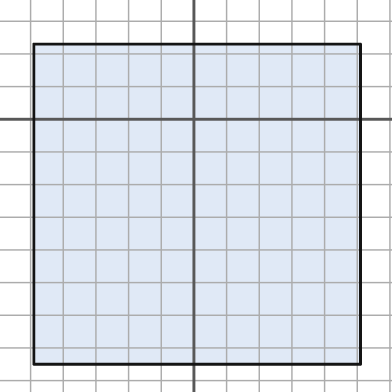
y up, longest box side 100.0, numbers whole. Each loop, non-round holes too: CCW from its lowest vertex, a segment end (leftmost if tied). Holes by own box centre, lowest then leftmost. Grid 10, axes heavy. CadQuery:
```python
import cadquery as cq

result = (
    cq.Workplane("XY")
    .moveTo(-49.0, -75.0)
    .lineTo(51.0, -75.0)
    .lineTo(51.0, 23.0)
    .lineTo(-49.0, 23.0)
    .close()
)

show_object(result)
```